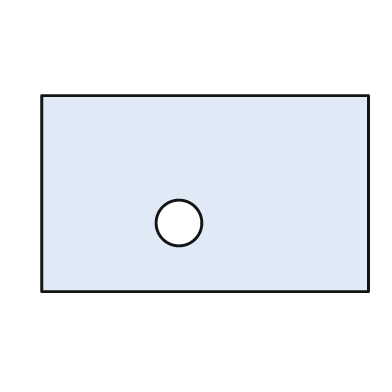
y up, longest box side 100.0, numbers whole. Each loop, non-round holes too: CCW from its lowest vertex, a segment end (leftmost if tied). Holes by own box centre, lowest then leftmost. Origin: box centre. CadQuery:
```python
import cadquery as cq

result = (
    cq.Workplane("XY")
    .moveTo(-50.0, -30.0)
    .lineTo(50.0, -30.0)
    .lineTo(50.0, 30.0)
    .lineTo(-50.0, 30.0)
    .close()
    .moveTo(-8.0, -9.0)
    .circle(7.0)
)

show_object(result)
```